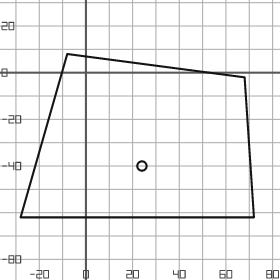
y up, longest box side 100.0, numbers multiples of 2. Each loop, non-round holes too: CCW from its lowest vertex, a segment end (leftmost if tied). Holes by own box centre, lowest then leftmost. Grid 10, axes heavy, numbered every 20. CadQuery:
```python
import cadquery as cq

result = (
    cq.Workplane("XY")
    .moveTo(-28.0, -62.0)
    .lineTo(72.0, -62.0)
    .lineTo(68.0, -2.0)
    .lineTo(-8.0, 8.0)
    .close()
    .moveTo(24.0, -40.0)
    .circle(2.0)
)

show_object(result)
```